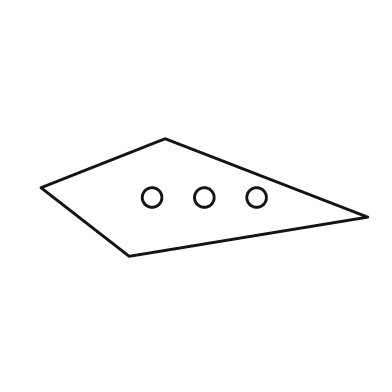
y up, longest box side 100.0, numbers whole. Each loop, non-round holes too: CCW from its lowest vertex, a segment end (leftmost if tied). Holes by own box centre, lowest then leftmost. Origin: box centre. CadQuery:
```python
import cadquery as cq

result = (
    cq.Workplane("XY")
    .moveTo(-23.0, -18.0)
    .lineTo(50.0, -6.0)
    .lineTo(-12.0, 18.0)
    .lineTo(-50.0, 3.0)
    .close()
    .moveTo(-16.0, 0.0)
    .circle(3.0)
    .moveTo(0.0, 0.0)
    .circle(3.0)
    .moveTo(16.0, 0.0)
    .circle(3.0)
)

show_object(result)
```